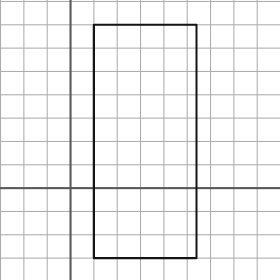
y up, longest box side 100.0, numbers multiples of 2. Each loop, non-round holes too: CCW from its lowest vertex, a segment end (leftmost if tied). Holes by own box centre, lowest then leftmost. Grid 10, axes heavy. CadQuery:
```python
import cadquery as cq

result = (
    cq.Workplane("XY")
    .moveTo(10.0, -30.0)
    .lineTo(54.0, -30.0)
    .lineTo(54.0, 70.0)
    .lineTo(10.0, 70.0)
    .close()
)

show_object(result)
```